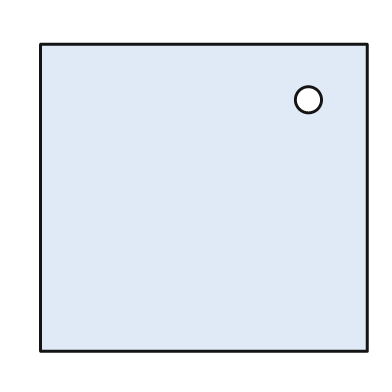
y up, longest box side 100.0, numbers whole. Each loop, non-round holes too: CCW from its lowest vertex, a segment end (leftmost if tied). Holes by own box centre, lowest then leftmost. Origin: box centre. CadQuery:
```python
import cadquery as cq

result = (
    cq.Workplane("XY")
    .moveTo(-50.0, -47.0)
    .lineTo(50.0, -47.0)
    .lineTo(50.0, 47.0)
    .lineTo(-50.0, 47.0)
    .close()
    .moveTo(32.0, 30.0)
    .circle(4.0)
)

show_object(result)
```